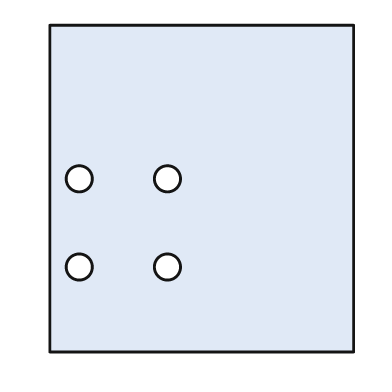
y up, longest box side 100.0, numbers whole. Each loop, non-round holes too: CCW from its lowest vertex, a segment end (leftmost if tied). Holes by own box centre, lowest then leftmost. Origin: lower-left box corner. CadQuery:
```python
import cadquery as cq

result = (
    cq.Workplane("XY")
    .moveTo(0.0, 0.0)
    .lineTo(93.0, 0.0)
    .lineTo(93.0, 100.0)
    .lineTo(0.0, 100.0)
    .close()
    .moveTo(9.0, 26.0)
    .circle(4.0)
    .moveTo(36.0, 26.0)
    .circle(4.0)
    .moveTo(9.0, 53.0)
    .circle(4.0)
    .moveTo(36.0, 53.0)
    .circle(4.0)
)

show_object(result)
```